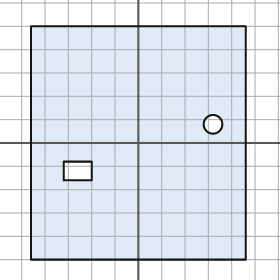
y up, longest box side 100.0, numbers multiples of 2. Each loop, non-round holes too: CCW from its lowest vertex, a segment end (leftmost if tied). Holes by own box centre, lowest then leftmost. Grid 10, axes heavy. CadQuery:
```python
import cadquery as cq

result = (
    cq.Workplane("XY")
    .moveTo(-46.0, -50.0)
    .lineTo(46.0, -50.0)
    .lineTo(46.0, 50.0)
    .lineTo(-46.0, 50.0)
    .close()
    .moveTo(-32.0, -16.0)
    .lineTo(-20.0, -16.0)
    .lineTo(-20.0, -8.0)
    .lineTo(-32.0, -8.0)
    .close()
    .moveTo(32.0, 8.0)
    .circle(4.0)
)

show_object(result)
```